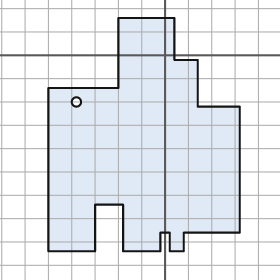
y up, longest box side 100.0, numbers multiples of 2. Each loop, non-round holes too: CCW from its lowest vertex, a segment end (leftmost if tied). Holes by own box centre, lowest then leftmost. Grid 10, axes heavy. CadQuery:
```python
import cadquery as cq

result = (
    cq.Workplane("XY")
    .moveTo(-50.0, -84.0)
    .lineTo(-30.0, -84.0)
    .lineTo(-30.0, -64.0)
    .lineTo(-18.0, -64.0)
    .lineTo(-18.0, -84.0)
    .lineTo(-2.0, -84.0)
    .lineTo(-2.0, -76.0)
    .lineTo(2.0, -76.0)
    .lineTo(2.0, -84.0)
    .lineTo(8.0, -84.0)
    .lineTo(8.0, -76.0)
    .lineTo(32.0, -76.0)
    .lineTo(32.0, -22.0)
    .lineTo(14.0, -22.0)
    .lineTo(14.0, -2.0)
    .lineTo(4.0, -2.0)
    .lineTo(4.0, 16.0)
    .lineTo(-20.0, 16.0)
    .lineTo(-20.0, -14.0)
    .lineTo(-50.0, -14.0)
    .close()
    .moveTo(-38.0, -20.0)
    .circle(2.0)
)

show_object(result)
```